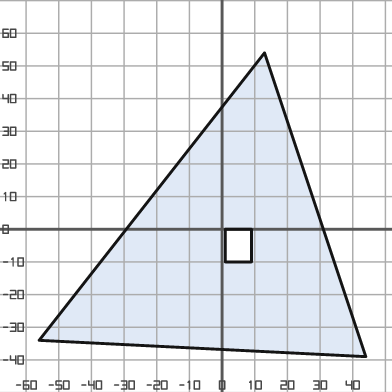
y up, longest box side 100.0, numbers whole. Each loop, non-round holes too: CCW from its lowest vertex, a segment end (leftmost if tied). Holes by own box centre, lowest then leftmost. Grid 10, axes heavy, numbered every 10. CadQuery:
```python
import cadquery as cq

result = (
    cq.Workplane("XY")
    .moveTo(44.0, -39.0)
    .lineTo(13.0, 54.0)
    .lineTo(-56.0, -34.0)
    .close()
    .moveTo(1.0, -10.0)
    .lineTo(9.0, -10.0)
    .lineTo(9.0, 0.0)
    .lineTo(1.0, 0.0)
    .close()
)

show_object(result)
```